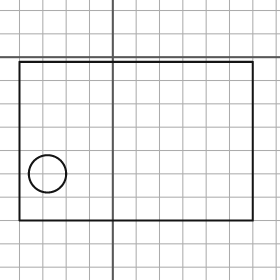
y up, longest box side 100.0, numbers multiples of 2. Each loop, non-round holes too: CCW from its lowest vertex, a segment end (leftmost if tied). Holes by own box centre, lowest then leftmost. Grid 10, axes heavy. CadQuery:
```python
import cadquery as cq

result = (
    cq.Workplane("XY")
    .moveTo(-40.0, -70.0)
    .lineTo(60.0, -70.0)
    .lineTo(60.0, -2.0)
    .lineTo(-40.0, -2.0)
    .close()
    .moveTo(-28.0, -50.0)
    .circle(8.0)
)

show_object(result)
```